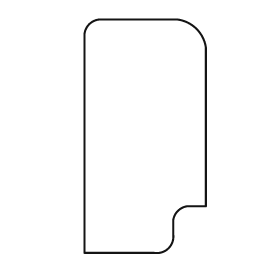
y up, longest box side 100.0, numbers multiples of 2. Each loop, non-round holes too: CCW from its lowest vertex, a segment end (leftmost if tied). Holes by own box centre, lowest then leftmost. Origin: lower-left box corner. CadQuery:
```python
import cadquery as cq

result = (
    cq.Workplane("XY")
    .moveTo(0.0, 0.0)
    .lineTo(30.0, 0.0)
    .threePointArc((36.0, 2.0), (38.0, 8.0))
    .lineTo(38.0, 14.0)
    .threePointArc((40.0, 18.0), (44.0, 20.0))
    .lineTo(52.0, 20.0)
    .lineTo(52.0, 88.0)
    .threePointArc((48.0, 96.0), (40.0, 100.0))
    .lineTo(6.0, 100.0)
    .threePointArc((2.0, 98.0), (0.0, 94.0))
    .close()
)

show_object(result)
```